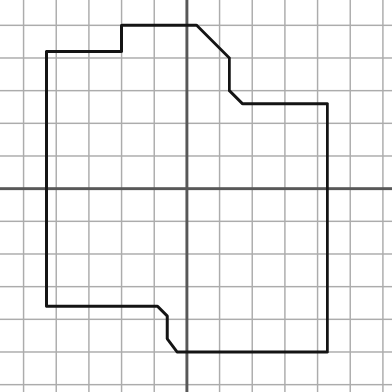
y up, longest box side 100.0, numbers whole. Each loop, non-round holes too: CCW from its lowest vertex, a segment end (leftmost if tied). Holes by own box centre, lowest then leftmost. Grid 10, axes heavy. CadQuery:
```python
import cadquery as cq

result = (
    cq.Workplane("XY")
    .moveTo(-3.0, -50.0)
    .lineTo(43.0, -50.0)
    .lineTo(43.0, 26.0)
    .lineTo(17.0, 26.0)
    .lineTo(13.0, 30.0)
    .lineTo(13.0, 40.0)
    .lineTo(3.0, 50.0)
    .lineTo(-20.0, 50.0)
    .lineTo(-20.0, 42.0)
    .lineTo(-43.0, 42.0)
    .lineTo(-43.0, -36.0)
    .lineTo(-9.0, -36.0)
    .lineTo(-6.0, -39.0)
    .lineTo(-6.0, -46.0)
    .close()
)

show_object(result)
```